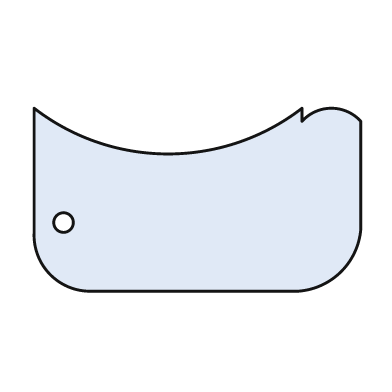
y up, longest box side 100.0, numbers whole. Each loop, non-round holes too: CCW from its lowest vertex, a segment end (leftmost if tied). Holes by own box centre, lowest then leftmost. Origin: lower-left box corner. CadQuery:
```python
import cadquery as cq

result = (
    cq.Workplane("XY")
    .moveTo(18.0, 0.0)
    .lineTo(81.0, 0.0)
    .threePointArc((94.0, 6.0), (100.0, 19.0))
    .lineTo(100.0, 52.0)
    .threePointArc((91.0, 56.0), (82.0, 52.0))
    .lineTo(82.0, 56.0)
    .threePointArc((41.0, 42.0), (0.0, 56.0))
    .lineTo(0.0, 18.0)
    .threePointArc((5.0, 5.0), (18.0, 0.0))
    .close()
    .moveTo(9.0, 21.0)
    .circle(3.0)
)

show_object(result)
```